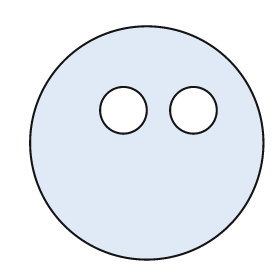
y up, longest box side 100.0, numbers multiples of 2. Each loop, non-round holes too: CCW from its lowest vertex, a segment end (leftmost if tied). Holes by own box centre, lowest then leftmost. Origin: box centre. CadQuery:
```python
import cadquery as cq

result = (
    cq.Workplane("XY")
    .moveTo(0.0, 0.0)
    .circle(50.0)
    .moveTo(-10.0, 14.0)
    .circle(10.0)
    .moveTo(20.0, 14.0)
    .circle(10.0)
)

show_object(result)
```